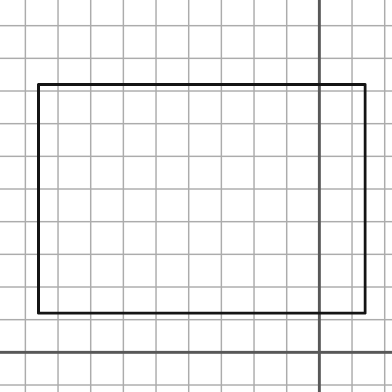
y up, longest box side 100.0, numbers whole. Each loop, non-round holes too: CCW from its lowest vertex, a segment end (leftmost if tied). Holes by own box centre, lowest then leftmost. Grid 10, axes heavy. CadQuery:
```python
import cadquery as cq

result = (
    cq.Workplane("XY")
    .moveTo(-86.0, 12.0)
    .lineTo(14.0, 12.0)
    .lineTo(14.0, 82.0)
    .lineTo(-86.0, 82.0)
    .close()
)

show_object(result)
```